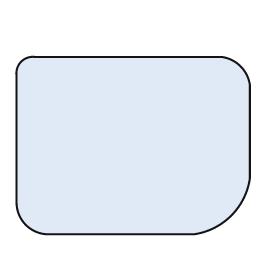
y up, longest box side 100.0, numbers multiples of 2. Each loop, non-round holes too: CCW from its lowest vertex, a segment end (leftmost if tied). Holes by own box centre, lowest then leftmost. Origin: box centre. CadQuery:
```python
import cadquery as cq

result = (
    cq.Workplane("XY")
    .moveTo(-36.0, -38.0)
    .lineTo(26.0, -38.0)
    .threePointArc((42.0, -30.0), (50.0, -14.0))
    .lineTo(50.0, 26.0)
    .threePointArc((46.0, 34.0), (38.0, 38.0))
    .lineTo(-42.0, 38.0)
    .threePointArc((-48.0, 36.0), (-50.0, 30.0))
    .lineTo(-50.0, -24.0)
    .threePointArc((-46.0, -34.0), (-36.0, -38.0))
    .close()
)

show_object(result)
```